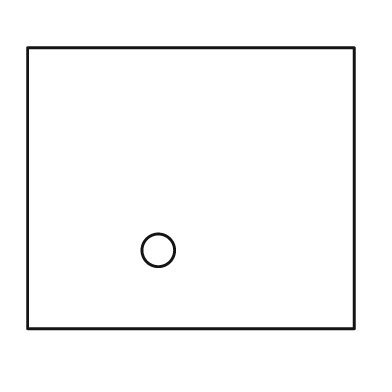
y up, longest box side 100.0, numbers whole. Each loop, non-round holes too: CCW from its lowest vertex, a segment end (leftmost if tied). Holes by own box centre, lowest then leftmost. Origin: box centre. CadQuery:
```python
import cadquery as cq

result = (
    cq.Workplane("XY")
    .moveTo(-50.0, -43.0)
    .lineTo(50.0, -43.0)
    .lineTo(50.0, 43.0)
    .lineTo(-50.0, 43.0)
    .close()
    .moveTo(-10.0, -19.0)
    .circle(5.0)
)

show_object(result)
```